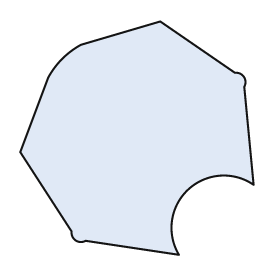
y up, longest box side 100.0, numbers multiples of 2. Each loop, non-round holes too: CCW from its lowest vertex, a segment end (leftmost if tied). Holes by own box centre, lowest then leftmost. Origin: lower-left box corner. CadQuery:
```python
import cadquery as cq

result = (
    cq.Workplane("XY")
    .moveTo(68.0, 0.0)
    .threePointArc((72.0, 28.0), (100.0, 30.0))
    .lineTo(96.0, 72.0)
    .threePointArc((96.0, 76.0), (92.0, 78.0))
    .lineTo(60.0, 100.0)
    .lineTo(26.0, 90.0)
    .threePointArc((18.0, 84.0), (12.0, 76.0))
    .lineTo(0.0, 44.0)
    .lineTo(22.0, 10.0)
    .threePointArc((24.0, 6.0), (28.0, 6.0))
    .close()
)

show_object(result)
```